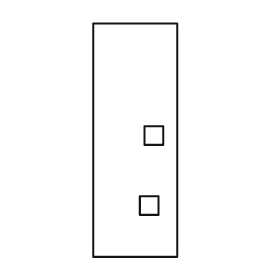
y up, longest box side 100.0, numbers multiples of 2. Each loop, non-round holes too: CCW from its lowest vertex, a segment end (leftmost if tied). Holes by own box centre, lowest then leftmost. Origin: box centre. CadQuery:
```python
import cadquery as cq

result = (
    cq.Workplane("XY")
    .moveTo(-18.0, -50.0)
    .lineTo(18.0, -50.0)
    .lineTo(18.0, 50.0)
    .lineTo(-18.0, 50.0)
    .close()
    .moveTo(2.0, -32.0)
    .lineTo(10.0, -32.0)
    .lineTo(10.0, -24.0)
    .lineTo(2.0, -24.0)
    .close()
    .moveTo(4.0, -2.0)
    .lineTo(12.0, -2.0)
    .lineTo(12.0, 6.0)
    .lineTo(4.0, 6.0)
    .close()
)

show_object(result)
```